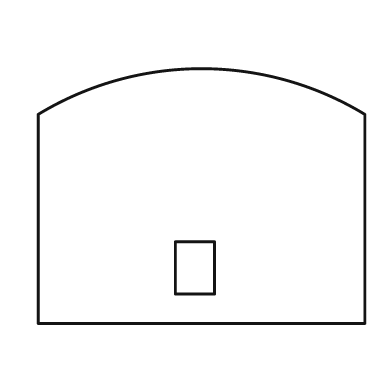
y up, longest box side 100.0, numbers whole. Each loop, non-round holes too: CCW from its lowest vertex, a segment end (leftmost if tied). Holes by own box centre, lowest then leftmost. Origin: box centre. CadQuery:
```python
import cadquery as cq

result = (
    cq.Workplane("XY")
    .moveTo(-50.0, -39.0)
    .lineTo(50.0, -39.0)
    .lineTo(50.0, 25.0)
    .threePointArc((0.0, 39.0), (-50.0, 25.0))
    .close()
    .moveTo(-8.0, -30.0)
    .lineTo(4.0, -30.0)
    .lineTo(4.0, -14.0)
    .lineTo(-8.0, -14.0)
    .close()
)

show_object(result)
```